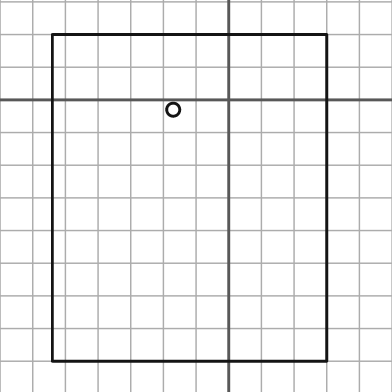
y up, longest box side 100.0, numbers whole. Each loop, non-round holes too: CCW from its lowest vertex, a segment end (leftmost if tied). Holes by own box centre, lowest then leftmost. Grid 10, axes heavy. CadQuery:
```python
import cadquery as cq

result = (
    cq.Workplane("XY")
    .moveTo(-54.0, -80.0)
    .lineTo(30.0, -80.0)
    .lineTo(30.0, 20.0)
    .lineTo(-54.0, 20.0)
    .close()
    .moveTo(-17.0, -3.0)
    .circle(2.0)
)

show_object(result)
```